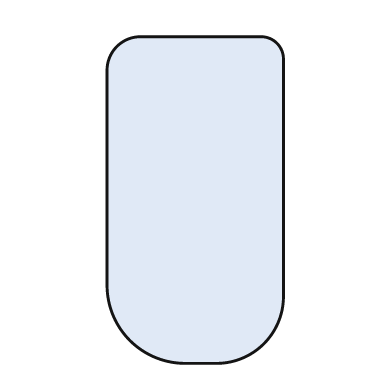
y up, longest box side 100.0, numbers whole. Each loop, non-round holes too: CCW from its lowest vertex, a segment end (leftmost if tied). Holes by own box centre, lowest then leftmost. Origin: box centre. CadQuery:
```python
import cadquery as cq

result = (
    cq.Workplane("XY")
    .moveTo(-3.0, -50.0)
    .lineTo(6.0, -50.0)
    .threePointArc((21.0, -44.0), (27.0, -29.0))
    .lineTo(27.0, 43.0)
    .threePointArc((25.0, 48.0), (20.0, 50.0))
    .lineTo(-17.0, 50.0)
    .threePointArc((-24.0, 47.0), (-27.0, 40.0))
    .lineTo(-27.0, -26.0)
    .threePointArc((-20.0, -43.0), (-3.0, -50.0))
    .close()
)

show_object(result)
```